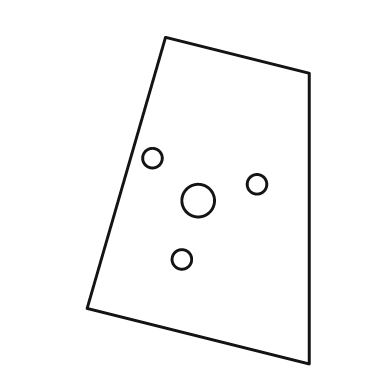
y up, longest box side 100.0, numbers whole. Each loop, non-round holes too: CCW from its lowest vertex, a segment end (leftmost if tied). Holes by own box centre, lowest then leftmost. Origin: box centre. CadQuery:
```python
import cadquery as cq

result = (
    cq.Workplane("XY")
    .moveTo(34.0, -50.0)
    .lineTo(34.0, 39.0)
    .lineTo(-10.0, 50.0)
    .lineTo(-34.0, -33.0)
    .close()
    .moveTo(-5.0, -18.0)
    .circle(3.0)
    .moveTo(0.0, 0.0)
    .circle(5.0)
    .moveTo(18.0, 5.0)
    .circle(3.0)
    .moveTo(-14.0, 13.0)
    .circle(3.0)
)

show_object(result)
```